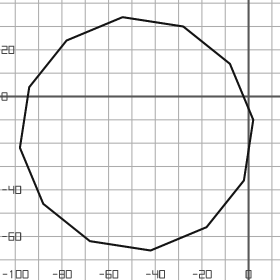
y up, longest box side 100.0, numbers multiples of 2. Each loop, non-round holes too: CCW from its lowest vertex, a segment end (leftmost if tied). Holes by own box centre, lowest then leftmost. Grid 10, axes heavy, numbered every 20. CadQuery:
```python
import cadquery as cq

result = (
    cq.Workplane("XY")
    .moveTo(-42.0, -66.0)
    .lineTo(-18.0, -56.0)
    .lineTo(-2.0, -36.0)
    .lineTo(2.0, -10.0)
    .lineTo(-8.0, 14.0)
    .lineTo(-28.0, 30.0)
    .lineTo(-54.0, 34.0)
    .lineTo(-78.0, 24.0)
    .lineTo(-94.0, 4.0)
    .lineTo(-98.0, -22.0)
    .lineTo(-88.0, -46.0)
    .lineTo(-68.0, -62.0)
    .close()
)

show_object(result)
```